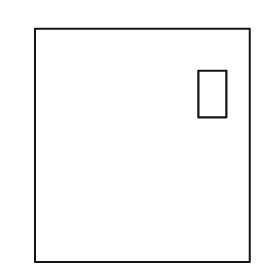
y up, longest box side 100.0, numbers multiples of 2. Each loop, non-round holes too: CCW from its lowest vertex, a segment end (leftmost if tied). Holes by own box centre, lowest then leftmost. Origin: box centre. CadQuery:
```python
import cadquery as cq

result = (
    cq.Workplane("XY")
    .moveTo(-46.0, -50.0)
    .lineTo(46.0, -50.0)
    .lineTo(46.0, 50.0)
    .lineTo(-46.0, 50.0)
    .close()
    .moveTo(24.0, 12.0)
    .lineTo(36.0, 12.0)
    .lineTo(36.0, 32.0)
    .lineTo(24.0, 32.0)
    .close()
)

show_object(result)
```